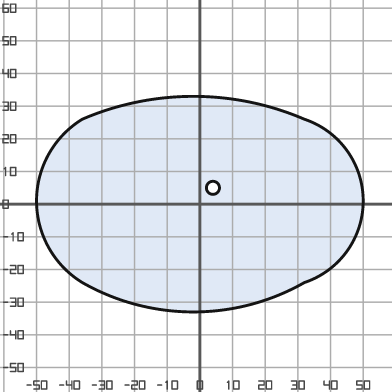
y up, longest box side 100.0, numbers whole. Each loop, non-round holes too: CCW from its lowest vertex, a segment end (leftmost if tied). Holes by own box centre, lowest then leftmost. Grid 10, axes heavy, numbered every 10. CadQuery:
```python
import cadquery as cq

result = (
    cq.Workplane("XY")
    .moveTo(-36.0, -24.0)
    .threePointArc((-2.0, -33.0), (32.0, -24.0))
    .threePointArc((50.0, 1.0), (32.0, 26.0))
    .threePointArc((-2.0, 33.0), (-36.0, 26.0))
    .threePointArc((-50.0, 1.0), (-36.0, -24.0))
    .close()
    .moveTo(4.0, 5.0)
    .circle(2.0)
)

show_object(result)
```